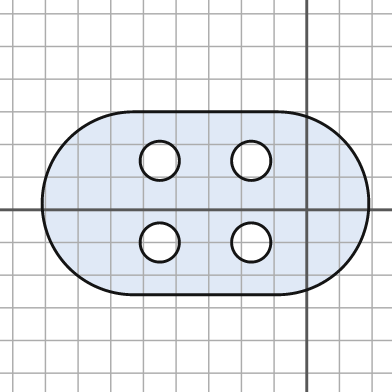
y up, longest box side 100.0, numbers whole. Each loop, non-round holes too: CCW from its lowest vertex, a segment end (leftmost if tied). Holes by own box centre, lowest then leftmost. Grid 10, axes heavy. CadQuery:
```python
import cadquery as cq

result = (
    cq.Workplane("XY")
    .moveTo(-53.0, -26.0)
    .lineTo(-9.0, -26.0)
    .threePointArc((19.0, 2.0), (-9.0, 30.0))
    .lineTo(-53.0, 30.0)
    .threePointArc((-81.0, 2.0), (-53.0, -26.0))
    .close()
    .moveTo(-45.0, -10.0)
    .circle(6.0)
    .moveTo(-17.0, -10.0)
    .circle(6.0)
    .moveTo(-45.0, 15.0)
    .circle(6.0)
    .moveTo(-17.0, 15.0)
    .circle(6.0)
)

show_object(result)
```